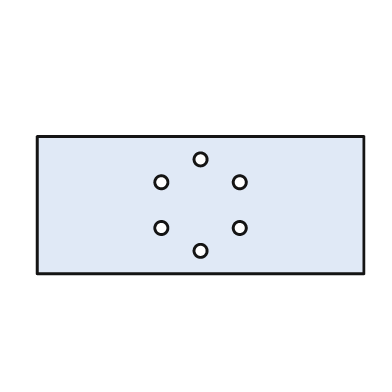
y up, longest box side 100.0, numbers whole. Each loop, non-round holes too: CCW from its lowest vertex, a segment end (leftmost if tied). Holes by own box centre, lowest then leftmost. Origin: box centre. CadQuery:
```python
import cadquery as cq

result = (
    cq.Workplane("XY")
    .moveTo(-50.0, -21.0)
    .lineTo(50.0, -21.0)
    .lineTo(50.0, 21.0)
    .lineTo(-50.0, 21.0)
    .close()
    .moveTo(0.0, -14.0)
    .circle(2.0)
    .moveTo(-12.0, -7.0)
    .circle(2.0)
    .moveTo(12.0, -7.0)
    .circle(2.0)
    .moveTo(-12.0, 7.0)
    .circle(2.0)
    .moveTo(12.0, 7.0)
    .circle(2.0)
    .moveTo(0.0, 14.0)
    .circle(2.0)
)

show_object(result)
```